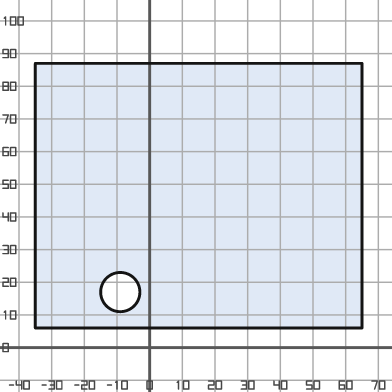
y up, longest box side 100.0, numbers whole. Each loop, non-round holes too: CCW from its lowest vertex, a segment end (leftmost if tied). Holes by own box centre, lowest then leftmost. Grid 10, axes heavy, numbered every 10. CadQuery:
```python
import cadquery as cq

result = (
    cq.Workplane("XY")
    .moveTo(-35.0, 6.0)
    .lineTo(65.0, 6.0)
    .lineTo(65.0, 87.0)
    .lineTo(-35.0, 87.0)
    .close()
    .moveTo(-9.0, 17.0)
    .circle(6.0)
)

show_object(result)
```